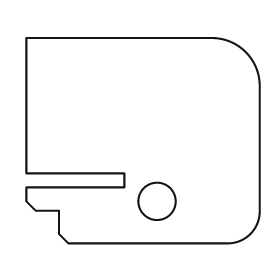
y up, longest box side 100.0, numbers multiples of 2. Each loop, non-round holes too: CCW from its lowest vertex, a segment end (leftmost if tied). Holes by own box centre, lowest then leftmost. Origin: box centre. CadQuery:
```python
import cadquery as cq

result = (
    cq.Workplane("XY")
    .moveTo(-32.0, -44.0)
    .lineTo(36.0, -44.0)
    .threePointArc((46.0, -40.0), (50.0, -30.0))
    .lineTo(50.0, 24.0)
    .threePointArc((44.0, 38.0), (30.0, 44.0))
    .lineTo(-50.0, 44.0)
    .lineTo(-50.0, -14.0)
    .lineTo(-8.0, -14.0)
    .lineTo(-8.0, -20.0)
    .lineTo(-50.0, -20.0)
    .lineTo(-50.0, -26.0)
    .lineTo(-46.0, -30.0)
    .lineTo(-36.0, -30.0)
    .lineTo(-36.0, -40.0)
    .close()
    .moveTo(6.0, -26.0)
    .circle(8.0)
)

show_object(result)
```